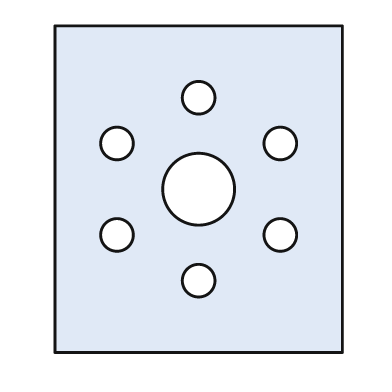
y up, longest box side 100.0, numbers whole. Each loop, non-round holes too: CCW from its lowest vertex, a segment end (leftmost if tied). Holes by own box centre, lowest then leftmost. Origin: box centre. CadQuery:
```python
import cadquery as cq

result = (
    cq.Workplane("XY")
    .moveTo(-44.0, -50.0)
    .lineTo(44.0, -50.0)
    .lineTo(44.0, 50.0)
    .lineTo(-44.0, 50.0)
    .close()
    .moveTo(0.0, -28.0)
    .circle(5.0)
    .moveTo(-25.0, -14.0)
    .circle(5.0)
    .moveTo(25.0, -14.0)
    .circle(5.0)
    .moveTo(0.0, 0.0)
    .circle(11.0)
    .moveTo(-25.0, 14.0)
    .circle(5.0)
    .moveTo(25.0, 14.0)
    .circle(5.0)
    .moveTo(0.0, 28.0)
    .circle(5.0)
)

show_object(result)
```